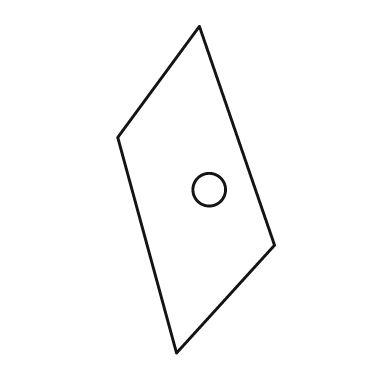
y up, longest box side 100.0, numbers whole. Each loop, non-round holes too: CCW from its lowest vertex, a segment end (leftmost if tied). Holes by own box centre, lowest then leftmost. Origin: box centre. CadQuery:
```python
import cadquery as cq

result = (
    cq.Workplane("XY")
    .moveTo(-6.0, -50.0)
    .lineTo(24.0, -17.0)
    .lineTo(1.0, 50.0)
    .lineTo(-24.0, 16.0)
    .close()
    .moveTo(4.0, 0.0)
    .circle(5.0)
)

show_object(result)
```